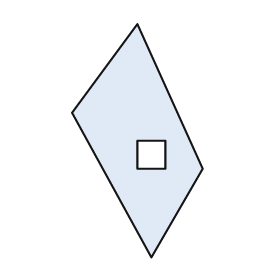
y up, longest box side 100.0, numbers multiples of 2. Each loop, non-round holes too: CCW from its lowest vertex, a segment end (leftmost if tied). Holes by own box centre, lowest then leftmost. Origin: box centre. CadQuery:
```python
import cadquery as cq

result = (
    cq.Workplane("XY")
    .moveTo(6.0, -50.0)
    .lineTo(28.0, -12.0)
    .lineTo(0.0, 50.0)
    .lineTo(-28.0, 12.0)
    .close()
    .moveTo(0.0, -12.0)
    .lineTo(12.0, -12.0)
    .lineTo(12.0, 0.0)
    .lineTo(0.0, 0.0)
    .close()
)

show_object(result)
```